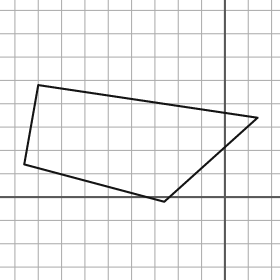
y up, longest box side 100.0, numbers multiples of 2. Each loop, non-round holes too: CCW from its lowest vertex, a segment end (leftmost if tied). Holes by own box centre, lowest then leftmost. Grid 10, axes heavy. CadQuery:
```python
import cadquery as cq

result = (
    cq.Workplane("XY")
    .moveTo(-26.0, -2.0)
    .lineTo(14.0, 34.0)
    .lineTo(-80.0, 48.0)
    .lineTo(-86.0, 14.0)
    .close()
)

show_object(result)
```